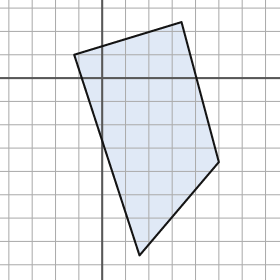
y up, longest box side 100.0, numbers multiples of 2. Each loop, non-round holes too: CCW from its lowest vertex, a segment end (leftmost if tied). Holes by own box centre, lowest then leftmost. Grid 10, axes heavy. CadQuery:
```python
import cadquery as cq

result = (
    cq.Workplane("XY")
    .moveTo(16.0, -76.0)
    .lineTo(50.0, -36.0)
    .lineTo(34.0, 24.0)
    .lineTo(-12.0, 10.0)
    .close()
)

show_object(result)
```